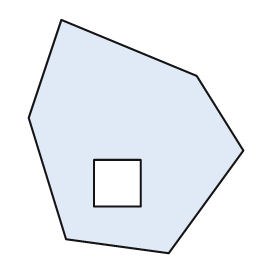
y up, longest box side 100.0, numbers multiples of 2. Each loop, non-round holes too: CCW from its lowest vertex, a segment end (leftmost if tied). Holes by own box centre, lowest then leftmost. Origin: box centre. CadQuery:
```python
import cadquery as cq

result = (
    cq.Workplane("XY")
    .moveTo(14.0, -50.0)
    .lineTo(46.0, -6.0)
    .lineTo(26.0, 26.0)
    .lineTo(-32.0, 50.0)
    .lineTo(-46.0, 8.0)
    .lineTo(-30.0, -44.0)
    .close()
    .moveTo(-18.0, -30.0)
    .lineTo(2.0, -30.0)
    .lineTo(2.0, -10.0)
    .lineTo(-18.0, -10.0)
    .close()
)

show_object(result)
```